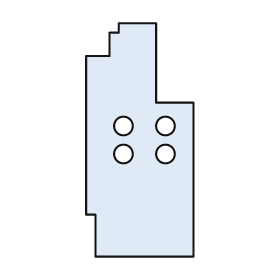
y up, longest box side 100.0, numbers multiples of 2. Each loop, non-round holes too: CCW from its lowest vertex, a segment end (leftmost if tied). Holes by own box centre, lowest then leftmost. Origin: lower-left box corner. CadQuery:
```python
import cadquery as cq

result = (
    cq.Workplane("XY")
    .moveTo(4.0, 0.0)
    .lineTo(46.0, 0.0)
    .lineTo(46.0, 66.0)
    .lineTo(30.0, 66.0)
    .lineTo(30.0, 100.0)
    .lineTo(14.0, 100.0)
    .lineTo(14.0, 96.0)
    .lineTo(10.0, 96.0)
    .lineTo(10.0, 86.0)
    .lineTo(0.0, 86.0)
    .lineTo(0.0, 18.0)
    .lineTo(4.0, 18.0)
    .close()
    .moveTo(16.0, 44.0)
    .circle(4.0)
    .moveTo(34.0, 44.0)
    .circle(4.0)
    .moveTo(16.0, 56.0)
    .circle(4.0)
    .moveTo(34.0, 56.0)
    .circle(4.0)
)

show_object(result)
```